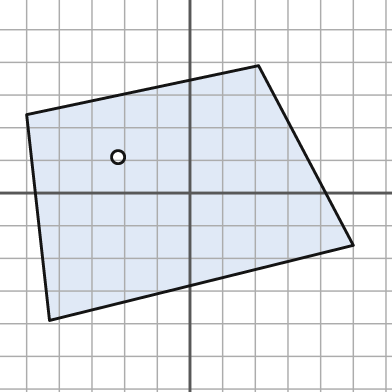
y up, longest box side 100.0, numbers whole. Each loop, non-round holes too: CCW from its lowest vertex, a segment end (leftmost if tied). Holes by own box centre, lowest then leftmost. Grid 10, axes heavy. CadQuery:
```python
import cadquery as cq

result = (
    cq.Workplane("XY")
    .moveTo(-43.0, -39.0)
    .lineTo(50.0, -16.0)
    .lineTo(21.0, 39.0)
    .lineTo(-50.0, 24.0)
    .close()
    .moveTo(-22.0, 11.0)
    .circle(2.0)
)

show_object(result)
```